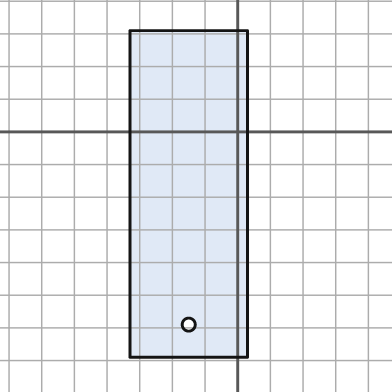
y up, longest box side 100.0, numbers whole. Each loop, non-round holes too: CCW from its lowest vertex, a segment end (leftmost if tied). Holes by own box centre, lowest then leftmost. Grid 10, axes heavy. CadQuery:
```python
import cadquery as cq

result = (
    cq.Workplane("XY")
    .moveTo(-33.0, -69.0)
    .lineTo(3.0, -69.0)
    .lineTo(3.0, 31.0)
    .lineTo(-33.0, 31.0)
    .close()
    .moveTo(-15.0, -59.0)
    .circle(2.0)
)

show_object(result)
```